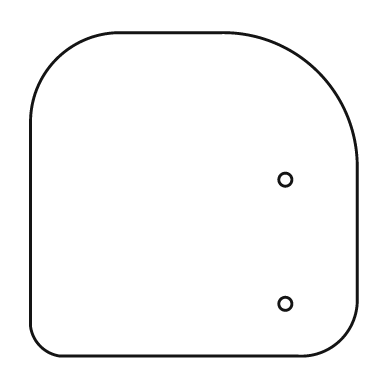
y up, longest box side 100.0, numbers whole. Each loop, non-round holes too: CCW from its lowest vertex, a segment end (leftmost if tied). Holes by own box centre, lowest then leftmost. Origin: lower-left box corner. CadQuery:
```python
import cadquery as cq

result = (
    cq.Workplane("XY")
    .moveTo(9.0, 0.0)
    .lineTo(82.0, 0.0)
    .threePointArc((95.0, 5.0), (100.0, 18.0))
    .lineTo(100.0, 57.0)
    .threePointArc((88.0, 87.0), (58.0, 99.0))
    .lineTo(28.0, 99.0)
    .threePointArc((8.0, 91.0), (0.0, 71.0))
    .lineTo(0.0, 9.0)
    .threePointArc((3.0, 3.0), (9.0, 0.0))
    .close()
    .moveTo(78.0, 16.0)
    .circle(2.0)
    .moveTo(78.0, 54.0)
    .circle(2.0)
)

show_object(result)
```